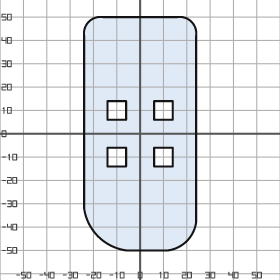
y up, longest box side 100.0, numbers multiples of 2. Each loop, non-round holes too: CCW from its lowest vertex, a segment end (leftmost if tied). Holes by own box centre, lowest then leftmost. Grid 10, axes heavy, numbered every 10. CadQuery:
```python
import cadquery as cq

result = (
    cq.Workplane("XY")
    .moveTo(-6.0, -50.0)
    .lineTo(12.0, -50.0)
    .threePointArc((20.0, -46.0), (24.0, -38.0))
    .lineTo(24.0, 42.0)
    .threePointArc((22.0, 48.0), (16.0, 50.0))
    .lineTo(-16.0, 50.0)
    .threePointArc((-22.0, 48.0), (-24.0, 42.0))
    .lineTo(-24.0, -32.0)
    .threePointArc((-18.0, -44.0), (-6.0, -50.0))
    .close()
    .moveTo(-14.0, -14.0)
    .lineTo(-6.0, -14.0)
    .lineTo(-6.0, -6.0)
    .lineTo(-14.0, -6.0)
    .close()
    .moveTo(6.0, -14.0)
    .lineTo(14.0, -14.0)
    .lineTo(14.0, -6.0)
    .lineTo(6.0, -6.0)
    .close()
    .moveTo(-14.0, 6.0)
    .lineTo(-6.0, 6.0)
    .lineTo(-6.0, 14.0)
    .lineTo(-14.0, 14.0)
    .close()
    .moveTo(6.0, 6.0)
    .lineTo(14.0, 6.0)
    .lineTo(14.0, 14.0)
    .lineTo(6.0, 14.0)
    .close()
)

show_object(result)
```